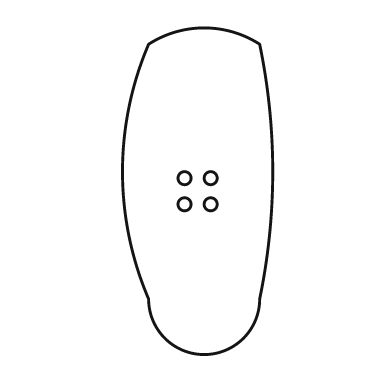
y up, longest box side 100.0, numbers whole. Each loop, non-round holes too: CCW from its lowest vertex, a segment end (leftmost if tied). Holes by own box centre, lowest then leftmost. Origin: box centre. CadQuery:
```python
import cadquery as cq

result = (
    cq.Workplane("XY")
    .moveTo(-15.0, -33.0)
    .threePointArc((2.0, -50.0), (19.0, -33.0))
    .threePointArc((23.0, 6.0), (19.0, 45.0))
    .threePointArc((2.0, 50.0), (-15.0, 45.0))
    .threePointArc((-23.0, 6.0), (-15.0, -33.0))
    .close()
    .moveTo(-4.0, -4.0)
    .circle(2.0)
    .moveTo(4.0, -4.0)
    .circle(2.0)
    .moveTo(-4.0, 4.0)
    .circle(2.0)
    .moveTo(4.0, 4.0)
    .circle(2.0)
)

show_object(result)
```